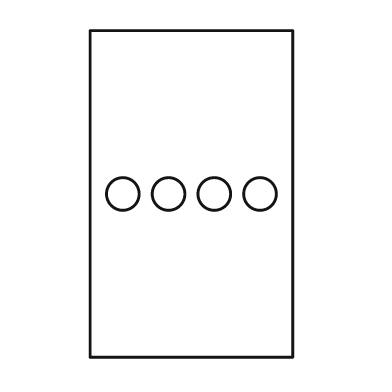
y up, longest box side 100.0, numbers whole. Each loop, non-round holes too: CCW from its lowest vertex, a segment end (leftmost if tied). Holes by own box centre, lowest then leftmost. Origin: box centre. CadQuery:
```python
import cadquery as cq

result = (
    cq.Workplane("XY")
    .moveTo(-31.0, -50.0)
    .lineTo(31.0, -50.0)
    .lineTo(31.0, 50.0)
    .lineTo(-31.0, 50.0)
    .close()
    .moveTo(-21.0, 0.0)
    .circle(5.0)
    .moveTo(-7.0, 0.0)
    .circle(5.0)
    .moveTo(7.0, 0.0)
    .circle(5.0)
    .moveTo(21.0, 0.0)
    .circle(5.0)
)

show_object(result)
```